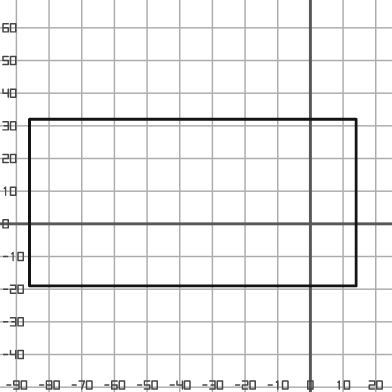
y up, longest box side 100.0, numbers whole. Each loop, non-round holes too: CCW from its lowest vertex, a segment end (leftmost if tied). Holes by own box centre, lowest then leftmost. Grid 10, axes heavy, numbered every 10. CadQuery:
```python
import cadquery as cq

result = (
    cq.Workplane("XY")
    .moveTo(-86.0, -19.0)
    .lineTo(14.0, -19.0)
    .lineTo(14.0, 32.0)
    .lineTo(-86.0, 32.0)
    .close()
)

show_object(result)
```